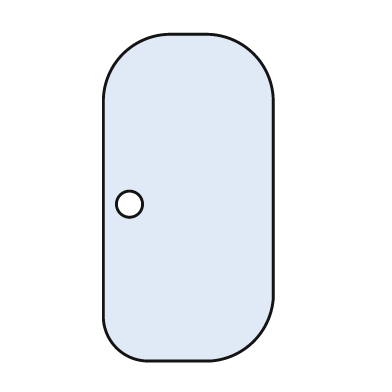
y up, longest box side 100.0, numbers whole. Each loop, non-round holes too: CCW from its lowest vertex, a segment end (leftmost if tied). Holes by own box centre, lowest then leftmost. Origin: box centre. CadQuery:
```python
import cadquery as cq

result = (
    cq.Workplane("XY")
    .moveTo(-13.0, -50.0)
    .lineTo(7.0, -50.0)
    .threePointArc((20.0, -44.0), (26.0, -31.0))
    .lineTo(26.0, 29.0)
    .threePointArc((20.0, 44.0), (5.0, 50.0))
    .lineTo(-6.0, 50.0)
    .threePointArc((-20.0, 44.0), (-26.0, 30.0))
    .lineTo(-26.0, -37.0)
    .threePointArc((-22.0, -46.0), (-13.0, -50.0))
    .close()
    .moveTo(-18.0, -2.0)
    .circle(4.0)
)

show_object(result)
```